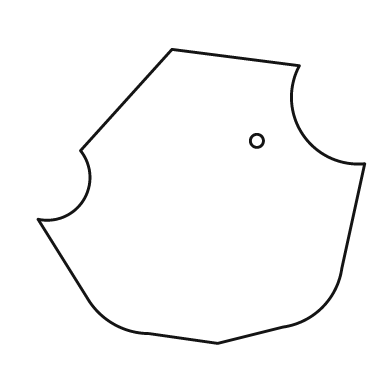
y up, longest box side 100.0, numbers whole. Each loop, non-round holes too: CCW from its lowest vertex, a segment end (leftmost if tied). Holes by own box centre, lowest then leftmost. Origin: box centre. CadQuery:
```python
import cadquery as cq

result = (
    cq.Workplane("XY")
    .moveTo(5.0, -45.0)
    .lineTo(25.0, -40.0)
    .threePointArc((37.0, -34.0), (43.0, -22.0))
    .lineTo(50.0, 10.0)
    .threePointArc((31.0, 19.0), (30.0, 40.0))
    .lineTo(-9.0, 45.0)
    .lineTo(-37.0, 14.0)
    .threePointArc((-36.0, -1.0), (-50.0, -7.0))
    .lineTo(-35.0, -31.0)
    .threePointArc((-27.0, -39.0), (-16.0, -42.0))
    .close()
    .moveTo(17.0, 17.0)
    .circle(2.0)
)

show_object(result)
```